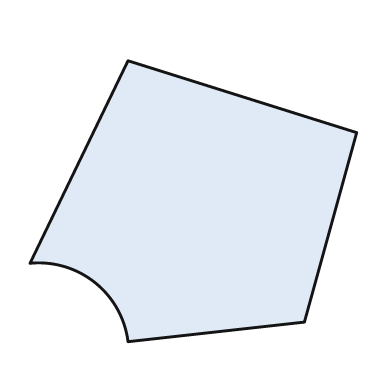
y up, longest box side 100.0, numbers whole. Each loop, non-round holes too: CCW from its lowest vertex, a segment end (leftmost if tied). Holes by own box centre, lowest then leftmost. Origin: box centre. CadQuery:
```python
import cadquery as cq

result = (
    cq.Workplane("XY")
    .moveTo(-20.0, -43.0)
    .lineTo(34.0, -37.0)
    .lineTo(50.0, 21.0)
    .lineTo(-20.0, 43.0)
    .lineTo(-50.0, -19.0)
    .threePointArc((-30.0, -25.0), (-20.0, -43.0))
    .close()
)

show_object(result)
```